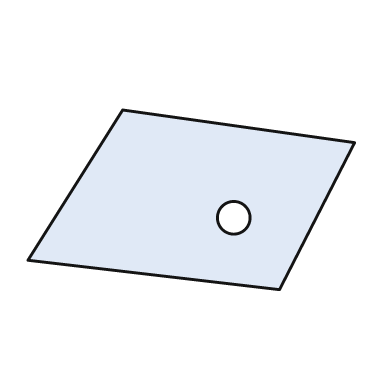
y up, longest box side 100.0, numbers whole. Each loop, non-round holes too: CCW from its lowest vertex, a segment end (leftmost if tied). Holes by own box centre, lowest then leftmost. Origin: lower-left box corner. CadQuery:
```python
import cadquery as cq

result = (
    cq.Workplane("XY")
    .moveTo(77.0, 0.0)
    .lineTo(100.0, 45.0)
    .lineTo(29.0, 55.0)
    .lineTo(0.0, 9.0)
    .close()
    .moveTo(63.0, 22.0)
    .circle(5.0)
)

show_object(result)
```